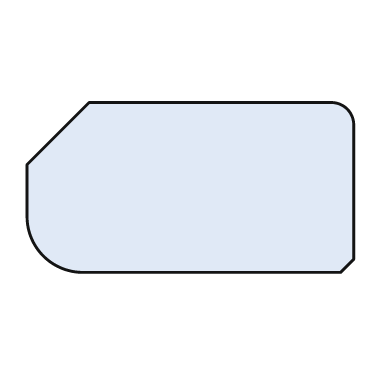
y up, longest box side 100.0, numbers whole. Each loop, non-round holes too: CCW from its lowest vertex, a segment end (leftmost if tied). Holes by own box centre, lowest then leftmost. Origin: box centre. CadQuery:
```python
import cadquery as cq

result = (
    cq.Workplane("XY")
    .moveTo(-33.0, -26.0)
    .lineTo(46.0, -26.0)
    .lineTo(50.0, -22.0)
    .lineTo(50.0, 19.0)
    .threePointArc((48.0, 24.0), (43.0, 26.0))
    .lineTo(-31.0, 26.0)
    .lineTo(-50.0, 7.0)
    .lineTo(-50.0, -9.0)
    .threePointArc((-45.0, -21.0), (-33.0, -26.0))
    .close()
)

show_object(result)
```